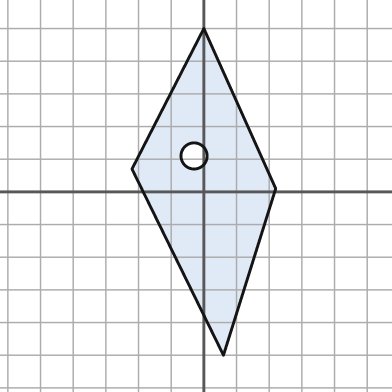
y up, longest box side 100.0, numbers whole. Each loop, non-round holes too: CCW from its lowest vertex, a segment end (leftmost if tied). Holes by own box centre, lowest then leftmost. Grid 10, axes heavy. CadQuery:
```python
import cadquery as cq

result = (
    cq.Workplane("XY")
    .moveTo(6.0, -50.0)
    .lineTo(22.0, 1.0)
    .lineTo(0.0, 50.0)
    .lineTo(-22.0, 7.0)
    .close()
    .moveTo(-3.0, 11.0)
    .circle(4.0)
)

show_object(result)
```